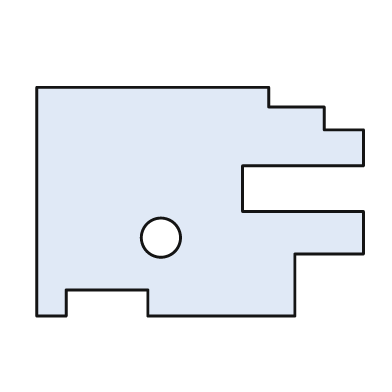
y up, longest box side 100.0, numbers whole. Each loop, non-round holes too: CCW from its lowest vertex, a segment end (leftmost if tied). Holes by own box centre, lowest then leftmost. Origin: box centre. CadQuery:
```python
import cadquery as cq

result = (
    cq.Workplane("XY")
    .moveTo(-50.0, -35.0)
    .lineTo(-41.0, -35.0)
    .lineTo(-41.0, -27.0)
    .lineTo(-16.0, -27.0)
    .lineTo(-16.0, -35.0)
    .lineTo(29.0, -35.0)
    .lineTo(29.0, -16.0)
    .lineTo(50.0, -16.0)
    .lineTo(50.0, -3.0)
    .lineTo(13.0, -3.0)
    .lineTo(13.0, 11.0)
    .lineTo(50.0, 11.0)
    .lineTo(50.0, 22.0)
    .lineTo(38.0, 22.0)
    .lineTo(38.0, 29.0)
    .lineTo(21.0, 29.0)
    .lineTo(21.0, 35.0)
    .lineTo(-50.0, 35.0)
    .close()
    .moveTo(-12.0, -11.0)
    .circle(6.0)
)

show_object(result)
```